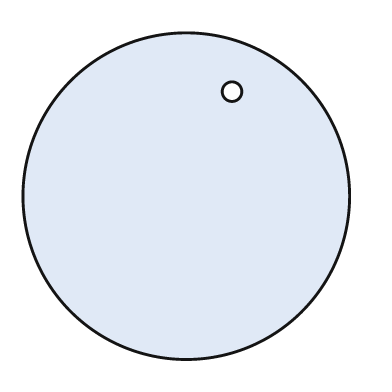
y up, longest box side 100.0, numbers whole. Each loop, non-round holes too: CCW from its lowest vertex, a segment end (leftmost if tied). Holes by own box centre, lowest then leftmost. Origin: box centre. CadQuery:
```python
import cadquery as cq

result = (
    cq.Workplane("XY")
    .moveTo(0.0, 0.0)
    .circle(50.0)
    .moveTo(14.0, 32.0)
    .circle(3.0)
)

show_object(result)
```